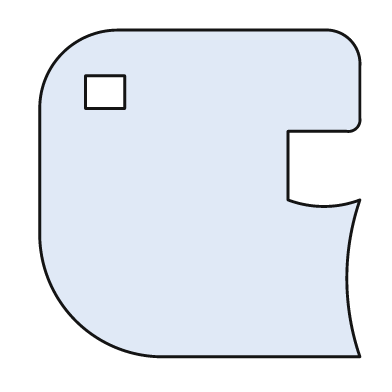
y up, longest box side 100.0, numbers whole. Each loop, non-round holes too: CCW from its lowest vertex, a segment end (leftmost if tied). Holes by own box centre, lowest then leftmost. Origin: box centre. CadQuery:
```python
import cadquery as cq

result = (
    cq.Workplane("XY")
    .moveTo(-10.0, -50.0)
    .lineTo(49.0, -50.0)
    .threePointArc((45.0, -26.0), (49.0, -2.0))
    .threePointArc((38.0, -4.0), (27.0, -2.0))
    .lineTo(27.0, 19.0)
    .lineTo(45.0, 19.0)
    .threePointArc((48.0, 20.0), (49.0, 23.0))
    .lineTo(49.0, 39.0)
    .threePointArc((46.0, 47.0), (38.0, 50.0))
    .lineTo(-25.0, 50.0)
    .threePointArc((-42.0, 43.0), (-49.0, 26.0))
    .lineTo(-49.0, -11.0)
    .threePointArc((-38.0, -39.0), (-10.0, -50.0))
    .close()
    .moveTo(-35.0, 26.0)
    .lineTo(-23.0, 26.0)
    .lineTo(-23.0, 36.0)
    .lineTo(-35.0, 36.0)
    .close()
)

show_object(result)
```